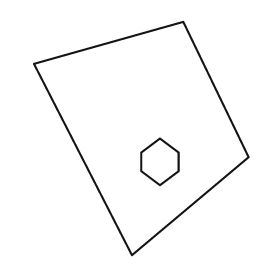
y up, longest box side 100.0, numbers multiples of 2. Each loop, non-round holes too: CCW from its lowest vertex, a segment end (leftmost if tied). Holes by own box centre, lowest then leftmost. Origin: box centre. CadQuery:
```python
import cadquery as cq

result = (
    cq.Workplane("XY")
    .moveTo(-4.0, -50.0)
    .lineTo(46.0, -8.0)
    .lineTo(18.0, 50.0)
    .lineTo(-46.0, 32.0)
    .close()
    .moveTo(8.0, -20.0)
    .lineTo(16.0, -14.0)
    .lineTo(16.0, -6.0)
    .lineTo(8.0, 0.0)
    .lineTo(0.0, -6.0)
    .lineTo(0.0, -14.0)
    .close()
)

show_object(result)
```